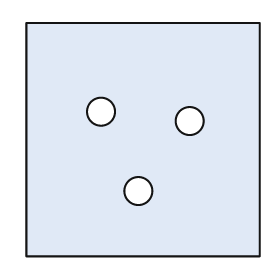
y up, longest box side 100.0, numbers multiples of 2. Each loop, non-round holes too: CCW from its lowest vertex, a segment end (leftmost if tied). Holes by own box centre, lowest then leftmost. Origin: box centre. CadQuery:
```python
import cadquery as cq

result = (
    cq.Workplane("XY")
    .moveTo(-50.0, -50.0)
    .lineTo(50.0, -50.0)
    .lineTo(50.0, 50.0)
    .lineTo(-50.0, 50.0)
    .close()
    .moveTo(-2.0, -22.0)
    .circle(6.0)
    .moveTo(20.0, 8.0)
    .circle(6.0)
    .moveTo(-18.0, 12.0)
    .circle(6.0)
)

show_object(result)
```